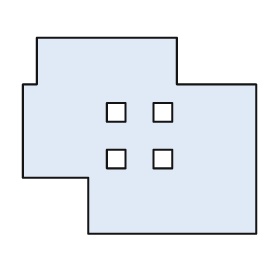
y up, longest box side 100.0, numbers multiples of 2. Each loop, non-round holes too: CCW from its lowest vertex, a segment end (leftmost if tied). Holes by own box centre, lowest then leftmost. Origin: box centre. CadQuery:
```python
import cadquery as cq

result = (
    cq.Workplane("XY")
    .moveTo(-22.0, -42.0)
    .lineTo(50.0, -42.0)
    .lineTo(50.0, 22.0)
    .lineTo(16.0, 22.0)
    .lineTo(16.0, 42.0)
    .lineTo(-44.0, 42.0)
    .lineTo(-44.0, 22.0)
    .lineTo(-50.0, 22.0)
    .lineTo(-50.0, -18.0)
    .lineTo(-22.0, -18.0)
    .close()
    .moveTo(-14.0, -14.0)
    .lineTo(-6.0, -14.0)
    .lineTo(-6.0, -6.0)
    .lineTo(-14.0, -6.0)
    .close()
    .moveTo(6.0, -14.0)
    .lineTo(14.0, -14.0)
    .lineTo(14.0, -6.0)
    .lineTo(6.0, -6.0)
    .close()
    .moveTo(-14.0, 6.0)
    .lineTo(-6.0, 6.0)
    .lineTo(-6.0, 14.0)
    .lineTo(-14.0, 14.0)
    .close()
    .moveTo(6.0, 6.0)
    .lineTo(14.0, 6.0)
    .lineTo(14.0, 14.0)
    .lineTo(6.0, 14.0)
    .close()
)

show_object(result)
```